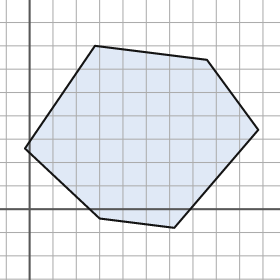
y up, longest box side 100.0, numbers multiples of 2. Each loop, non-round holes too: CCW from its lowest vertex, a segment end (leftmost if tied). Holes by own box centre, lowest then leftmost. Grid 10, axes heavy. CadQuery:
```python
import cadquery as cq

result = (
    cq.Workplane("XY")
    .moveTo(62.0, -8.0)
    .lineTo(98.0, 34.0)
    .lineTo(76.0, 64.0)
    .lineTo(28.0, 70.0)
    .lineTo(-2.0, 26.0)
    .lineTo(30.0, -4.0)
    .close()
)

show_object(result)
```